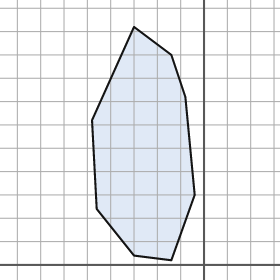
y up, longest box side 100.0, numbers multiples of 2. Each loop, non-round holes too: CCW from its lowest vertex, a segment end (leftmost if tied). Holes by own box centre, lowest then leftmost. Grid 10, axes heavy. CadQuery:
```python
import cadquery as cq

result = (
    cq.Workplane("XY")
    .moveTo(-14.0, 2.0)
    .lineTo(-4.0, 30.0)
    .lineTo(-8.0, 72.0)
    .lineTo(-14.0, 90.0)
    .lineTo(-30.0, 102.0)
    .lineTo(-48.0, 62.0)
    .lineTo(-46.0, 24.0)
    .lineTo(-30.0, 4.0)
    .close()
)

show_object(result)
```